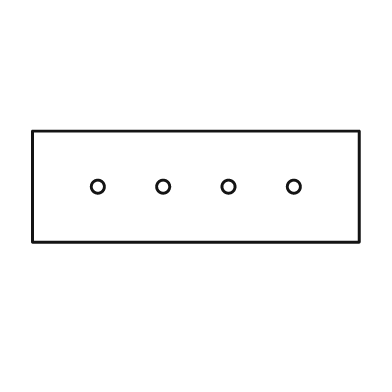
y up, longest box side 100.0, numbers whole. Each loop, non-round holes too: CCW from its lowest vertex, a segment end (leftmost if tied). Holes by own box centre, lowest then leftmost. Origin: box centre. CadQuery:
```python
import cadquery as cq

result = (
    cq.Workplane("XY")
    .moveTo(-50.0, -17.0)
    .lineTo(50.0, -17.0)
    .lineTo(50.0, 17.0)
    .lineTo(-50.0, 17.0)
    .close()
    .moveTo(-30.0, 0.0)
    .circle(2.0)
    .moveTo(-10.0, 0.0)
    .circle(2.0)
    .moveTo(10.0, 0.0)
    .circle(2.0)
    .moveTo(30.0, 0.0)
    .circle(2.0)
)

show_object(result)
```